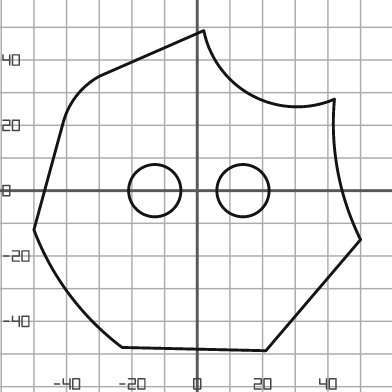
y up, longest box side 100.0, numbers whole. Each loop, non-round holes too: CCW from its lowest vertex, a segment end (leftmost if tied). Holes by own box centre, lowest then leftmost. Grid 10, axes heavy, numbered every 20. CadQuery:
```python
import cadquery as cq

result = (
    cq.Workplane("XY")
    .moveTo(21.0, -49.0)
    .lineTo(50.0, -15.0)
    .threePointArc((43.0, 6.0), (42.0, 28.0))
    .threePointArc((17.0, 29.0), (2.0, 49.0))
    .lineTo(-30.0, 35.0)
    .threePointArc((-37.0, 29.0), (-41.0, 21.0))
    .lineTo(-50.0, -12.0)
    .threePointArc((-39.0, -32.0), (-23.0, -48.0))
    .close()
    .moveTo(-13.0, 0.0)
    .circle(8.0)
    .moveTo(14.0, 0.0)
    .circle(8.0)
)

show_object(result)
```